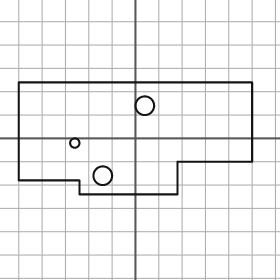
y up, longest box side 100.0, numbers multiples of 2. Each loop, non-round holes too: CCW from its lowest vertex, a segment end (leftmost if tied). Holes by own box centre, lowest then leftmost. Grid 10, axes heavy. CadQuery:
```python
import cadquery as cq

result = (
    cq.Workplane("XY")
    .moveTo(-24.0, -24.0)
    .lineTo(18.0, -24.0)
    .lineTo(18.0, -10.0)
    .lineTo(50.0, -10.0)
    .lineTo(50.0, 24.0)
    .lineTo(-50.0, 24.0)
    .lineTo(-50.0, -18.0)
    .lineTo(-24.0, -18.0)
    .close()
    .moveTo(-14.0, -16.0)
    .circle(4.0)
    .moveTo(-26.0, -2.0)
    .circle(2.0)
    .moveTo(4.0, 14.0)
    .circle(4.0)
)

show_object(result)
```